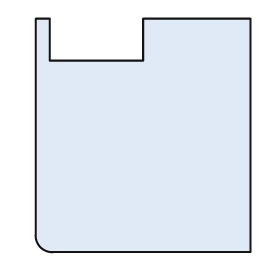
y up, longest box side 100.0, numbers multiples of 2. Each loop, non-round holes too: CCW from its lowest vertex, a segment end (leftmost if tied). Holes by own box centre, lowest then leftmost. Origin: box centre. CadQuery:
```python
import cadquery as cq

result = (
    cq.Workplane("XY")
    .moveTo(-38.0, -50.0)
    .lineTo(46.0, -50.0)
    .lineTo(46.0, 50.0)
    .lineTo(0.0, 50.0)
    .lineTo(0.0, 32.0)
    .lineTo(-40.0, 32.0)
    .lineTo(-40.0, 50.0)
    .lineTo(-46.0, 50.0)
    .lineTo(-46.0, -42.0)
    .threePointArc((-44.0, -48.0), (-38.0, -50.0))
    .close()
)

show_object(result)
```